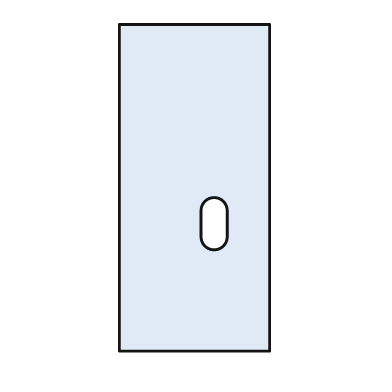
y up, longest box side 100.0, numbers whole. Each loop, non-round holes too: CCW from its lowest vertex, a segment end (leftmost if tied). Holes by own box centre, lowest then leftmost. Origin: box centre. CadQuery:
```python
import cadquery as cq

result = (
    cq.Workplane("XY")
    .moveTo(-23.0, -50.0)
    .lineTo(23.0, -50.0)
    .lineTo(23.0, 50.0)
    .lineTo(-23.0, 50.0)
    .close()
    .moveTo(2.0, -15.0)
    .threePointArc((6.0, -19.0), (10.0, -15.0))
    .lineTo(10.0, -7.0)
    .threePointArc((6.0, -3.0), (2.0, -7.0))
    .close()
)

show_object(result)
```